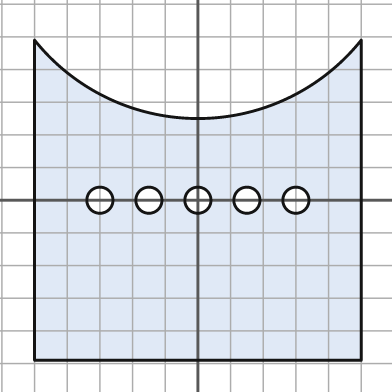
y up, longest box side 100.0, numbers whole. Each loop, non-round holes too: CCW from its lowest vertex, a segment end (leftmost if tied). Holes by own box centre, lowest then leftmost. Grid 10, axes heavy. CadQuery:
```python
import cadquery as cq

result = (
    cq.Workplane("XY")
    .moveTo(-50.0, -49.0)
    .lineTo(50.0, -49.0)
    .lineTo(50.0, 49.0)
    .threePointArc((0.0, 25.0), (-50.0, 49.0))
    .close()
    .moveTo(-30.0, 0.0)
    .circle(4.0)
    .moveTo(-15.0, 0.0)
    .circle(4.0)
    .moveTo(0.0, 0.0)
    .circle(4.0)
    .moveTo(15.0, 0.0)
    .circle(4.0)
    .moveTo(30.0, 0.0)
    .circle(4.0)
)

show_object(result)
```